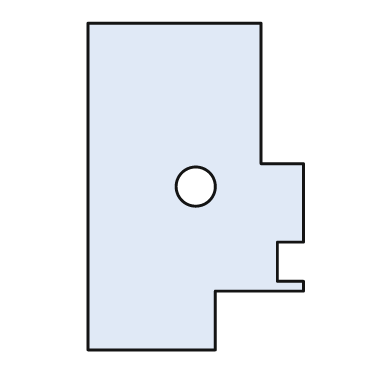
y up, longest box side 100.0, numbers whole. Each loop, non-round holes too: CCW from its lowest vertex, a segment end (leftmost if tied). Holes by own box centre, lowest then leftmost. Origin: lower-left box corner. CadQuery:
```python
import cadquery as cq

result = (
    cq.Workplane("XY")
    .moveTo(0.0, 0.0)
    .lineTo(39.0, 0.0)
    .lineTo(39.0, 18.0)
    .lineTo(66.0, 18.0)
    .lineTo(66.0, 21.0)
    .lineTo(58.0, 21.0)
    .lineTo(58.0, 33.0)
    .lineTo(66.0, 33.0)
    .lineTo(66.0, 57.0)
    .lineTo(53.0, 57.0)
    .lineTo(53.0, 100.0)
    .lineTo(0.0, 100.0)
    .close()
    .moveTo(33.0, 50.0)
    .circle(6.0)
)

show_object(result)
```